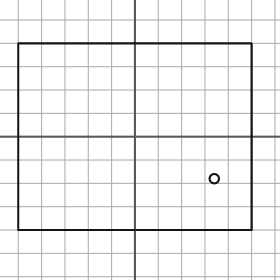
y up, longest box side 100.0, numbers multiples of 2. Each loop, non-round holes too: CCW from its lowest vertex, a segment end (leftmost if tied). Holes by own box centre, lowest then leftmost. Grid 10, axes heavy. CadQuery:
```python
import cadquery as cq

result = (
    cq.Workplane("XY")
    .moveTo(-50.0, -40.0)
    .lineTo(50.0, -40.0)
    .lineTo(50.0, 40.0)
    .lineTo(-50.0, 40.0)
    .close()
    .moveTo(34.0, -18.0)
    .circle(2.0)
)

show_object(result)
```